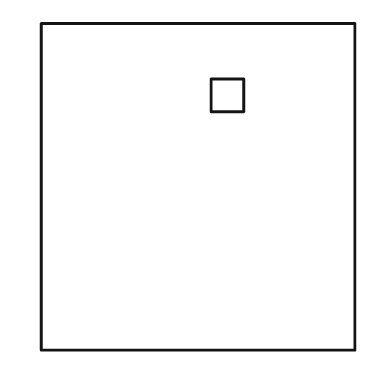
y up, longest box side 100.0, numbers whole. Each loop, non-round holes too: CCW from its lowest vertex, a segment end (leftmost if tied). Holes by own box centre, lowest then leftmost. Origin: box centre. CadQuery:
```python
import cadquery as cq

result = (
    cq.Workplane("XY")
    .moveTo(-48.0, -50.0)
    .lineTo(48.0, -50.0)
    .lineTo(48.0, 50.0)
    .lineTo(-48.0, 50.0)
    .close()
    .moveTo(4.0, 23.0)
    .lineTo(14.0, 23.0)
    .lineTo(14.0, 33.0)
    .lineTo(4.0, 33.0)
    .close()
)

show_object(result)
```